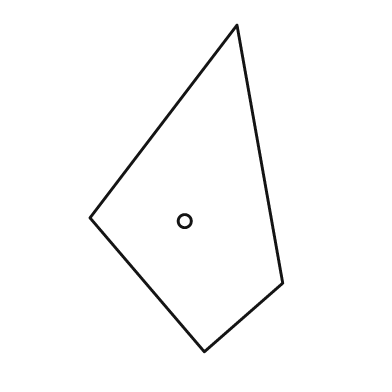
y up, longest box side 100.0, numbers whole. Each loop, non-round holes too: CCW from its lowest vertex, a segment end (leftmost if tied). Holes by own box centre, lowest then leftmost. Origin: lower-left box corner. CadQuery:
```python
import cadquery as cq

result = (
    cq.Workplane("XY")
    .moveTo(35.0, 0.0)
    .lineTo(59.0, 21.0)
    .lineTo(45.0, 100.0)
    .lineTo(0.0, 41.0)
    .close()
    .moveTo(29.0, 40.0)
    .circle(2.0)
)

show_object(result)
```